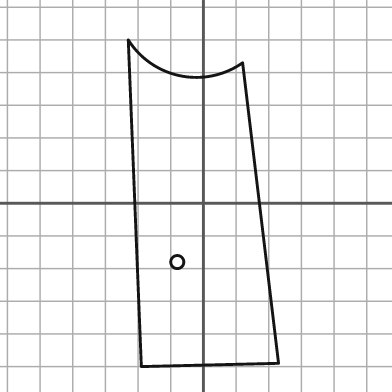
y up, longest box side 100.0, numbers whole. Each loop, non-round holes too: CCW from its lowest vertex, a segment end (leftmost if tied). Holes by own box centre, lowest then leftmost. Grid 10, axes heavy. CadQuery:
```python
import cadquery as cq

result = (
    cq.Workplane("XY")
    .moveTo(-19.0, -50.0)
    .lineTo(23.0, -49.0)
    .lineTo(12.0, 43.0)
    .threePointArc((-7.0, 39.0), (-23.0, 50.0))
    .close()
    .moveTo(-8.0, -18.0)
    .circle(2.0)
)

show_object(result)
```